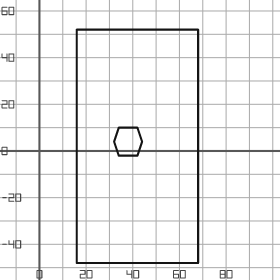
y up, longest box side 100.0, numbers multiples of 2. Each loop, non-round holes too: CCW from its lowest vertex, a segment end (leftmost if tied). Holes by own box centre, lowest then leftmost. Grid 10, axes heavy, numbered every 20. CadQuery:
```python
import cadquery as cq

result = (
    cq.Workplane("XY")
    .moveTo(16.0, -48.0)
    .lineTo(68.0, -48.0)
    .lineTo(68.0, 52.0)
    .lineTo(16.0, 52.0)
    .close()
    .moveTo(34.0, -2.0)
    .lineTo(42.0, -2.0)
    .lineTo(44.0, 4.0)
    .lineTo(42.0, 10.0)
    .lineTo(34.0, 10.0)
    .lineTo(32.0, 4.0)
    .close()
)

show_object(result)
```